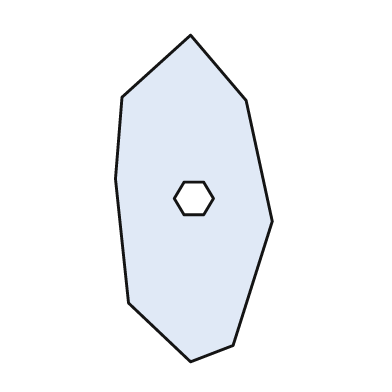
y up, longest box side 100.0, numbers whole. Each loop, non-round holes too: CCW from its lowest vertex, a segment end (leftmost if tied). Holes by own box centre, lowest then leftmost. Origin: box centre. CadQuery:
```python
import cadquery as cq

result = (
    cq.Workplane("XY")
    .moveTo(-1.0, -50.0)
    .lineTo(12.0, -45.0)
    .lineTo(24.0, -7.0)
    .lineTo(16.0, 30.0)
    .lineTo(-1.0, 50.0)
    .lineTo(-22.0, 31.0)
    .lineTo(-24.0, 6.0)
    .lineTo(-20.0, -32.0)
    .close()
    .moveTo(-3.0, -5.0)
    .lineTo(3.0, -5.0)
    .lineTo(6.0, 0.0)
    .lineTo(3.0, 5.0)
    .lineTo(-3.0, 5.0)
    .lineTo(-6.0, 0.0)
    .close()
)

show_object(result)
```